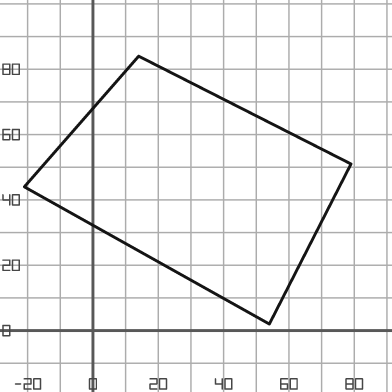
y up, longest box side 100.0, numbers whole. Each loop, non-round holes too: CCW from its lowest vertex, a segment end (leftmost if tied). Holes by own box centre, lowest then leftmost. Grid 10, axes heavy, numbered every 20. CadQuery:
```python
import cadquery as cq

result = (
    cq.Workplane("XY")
    .moveTo(54.0, 2.0)
    .lineTo(79.0, 51.0)
    .lineTo(14.0, 84.0)
    .lineTo(-21.0, 44.0)
    .close()
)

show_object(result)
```